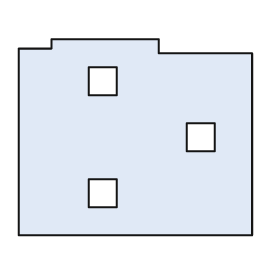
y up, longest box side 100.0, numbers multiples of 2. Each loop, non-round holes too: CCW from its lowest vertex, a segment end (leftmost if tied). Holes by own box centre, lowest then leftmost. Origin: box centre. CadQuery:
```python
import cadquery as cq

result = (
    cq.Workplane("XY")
    .moveTo(-50.0, -42.0)
    .lineTo(50.0, -42.0)
    .lineTo(50.0, 36.0)
    .lineTo(10.0, 36.0)
    .lineTo(10.0, 42.0)
    .lineTo(-36.0, 42.0)
    .lineTo(-36.0, 38.0)
    .lineTo(-50.0, 38.0)
    .close()
    .moveTo(-20.0, -30.0)
    .lineTo(-8.0, -30.0)
    .lineTo(-8.0, -18.0)
    .lineTo(-20.0, -18.0)
    .close()
    .moveTo(22.0, -6.0)
    .lineTo(34.0, -6.0)
    .lineTo(34.0, 6.0)
    .lineTo(22.0, 6.0)
    .close()
    .moveTo(-20.0, 18.0)
    .lineTo(-8.0, 18.0)
    .lineTo(-8.0, 30.0)
    .lineTo(-20.0, 30.0)
    .close()
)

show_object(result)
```